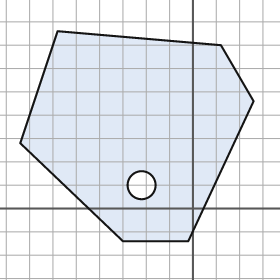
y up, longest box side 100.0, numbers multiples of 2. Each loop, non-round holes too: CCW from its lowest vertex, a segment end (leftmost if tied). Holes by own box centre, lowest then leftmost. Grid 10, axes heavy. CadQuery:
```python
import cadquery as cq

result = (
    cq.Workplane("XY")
    .moveTo(-30.0, -14.0)
    .lineTo(-2.0, -14.0)
    .lineTo(26.0, 46.0)
    .lineTo(12.0, 70.0)
    .lineTo(-58.0, 76.0)
    .lineTo(-74.0, 28.0)
    .close()
    .moveTo(-22.0, 10.0)
    .circle(6.0)
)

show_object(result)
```